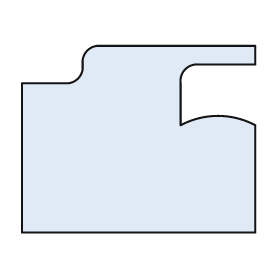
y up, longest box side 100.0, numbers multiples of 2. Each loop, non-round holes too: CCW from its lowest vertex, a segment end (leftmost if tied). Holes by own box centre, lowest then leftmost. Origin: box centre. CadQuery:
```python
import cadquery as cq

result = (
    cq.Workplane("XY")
    .moveTo(-50.0, -40.0)
    .lineTo(50.0, -40.0)
    .lineTo(50.0, 6.0)
    .threePointArc((34.0, 10.0), (18.0, 6.0))
    .lineTo(18.0, 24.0)
    .threePointArc((20.0, 30.0), (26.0, 32.0))
    .lineTo(50.0, 32.0)
    .lineTo(50.0, 40.0)
    .lineTo(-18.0, 40.0)
    .threePointArc((-22.0, 38.0), (-24.0, 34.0))
    .lineTo(-24.0, 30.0)
    .threePointArc((-26.0, 26.0), (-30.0, 24.0))
    .lineTo(-50.0, 24.0)
    .close()
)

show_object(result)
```